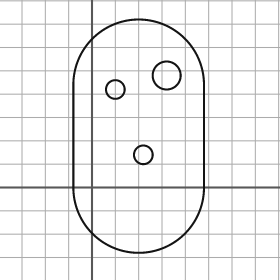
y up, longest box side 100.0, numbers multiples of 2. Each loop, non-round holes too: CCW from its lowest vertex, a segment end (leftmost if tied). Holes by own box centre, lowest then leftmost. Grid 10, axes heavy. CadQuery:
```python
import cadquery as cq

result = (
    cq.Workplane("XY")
    .moveTo(-8.0, 0.0)
    .threePointArc((20.0, -28.0), (48.0, 0.0))
    .lineTo(48.0, 44.0)
    .threePointArc((20.0, 72.0), (-8.0, 44.0))
    .close()
    .moveTo(22.0, 14.0)
    .circle(4.0)
    .moveTo(10.0, 42.0)
    .circle(4.0)
    .moveTo(32.0, 48.0)
    .circle(6.0)
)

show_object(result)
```